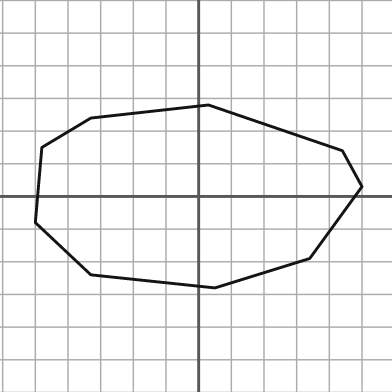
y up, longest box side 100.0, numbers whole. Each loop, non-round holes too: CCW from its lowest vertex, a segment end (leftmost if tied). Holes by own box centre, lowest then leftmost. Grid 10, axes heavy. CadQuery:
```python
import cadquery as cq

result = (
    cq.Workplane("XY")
    .moveTo(5.0, -28.0)
    .lineTo(34.0, -19.0)
    .lineTo(50.0, 3.0)
    .lineTo(44.0, 14.0)
    .lineTo(3.0, 28.0)
    .lineTo(-33.0, 24.0)
    .lineTo(-48.0, 15.0)
    .lineTo(-50.0, -8.0)
    .lineTo(-33.0, -24.0)
    .close()
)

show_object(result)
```